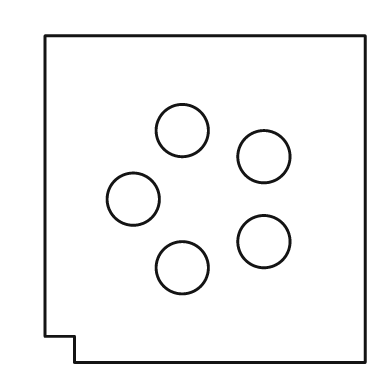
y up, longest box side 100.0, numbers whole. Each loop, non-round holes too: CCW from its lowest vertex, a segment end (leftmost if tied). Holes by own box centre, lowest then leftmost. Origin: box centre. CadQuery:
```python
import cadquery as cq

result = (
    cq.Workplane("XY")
    .moveTo(-40.0, -50.0)
    .lineTo(49.0, -50.0)
    .lineTo(49.0, 50.0)
    .lineTo(-49.0, 50.0)
    .lineTo(-49.0, -42.0)
    .lineTo(-40.0, -42.0)
    .close()
    .moveTo(-7.0, -21.0)
    .circle(8.0)
    .moveTo(18.0, -13.0)
    .circle(8.0)
    .moveTo(-22.0, 0.0)
    .circle(8.0)
    .moveTo(18.0, 13.0)
    .circle(8.0)
    .moveTo(-7.0, 21.0)
    .circle(8.0)
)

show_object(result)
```